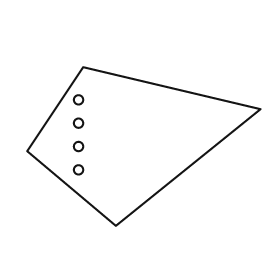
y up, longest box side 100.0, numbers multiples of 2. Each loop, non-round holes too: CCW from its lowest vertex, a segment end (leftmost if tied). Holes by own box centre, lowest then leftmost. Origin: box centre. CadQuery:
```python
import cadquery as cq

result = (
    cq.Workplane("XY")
    .moveTo(-12.0, -34.0)
    .lineTo(50.0, 16.0)
    .lineTo(-26.0, 34.0)
    .lineTo(-50.0, -2.0)
    .close()
    .moveTo(-28.0, -10.0)
    .circle(2.0)
    .moveTo(-28.0, 0.0)
    .circle(2.0)
    .moveTo(-28.0, 10.0)
    .circle(2.0)
    .moveTo(-28.0, 20.0)
    .circle(2.0)
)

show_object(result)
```